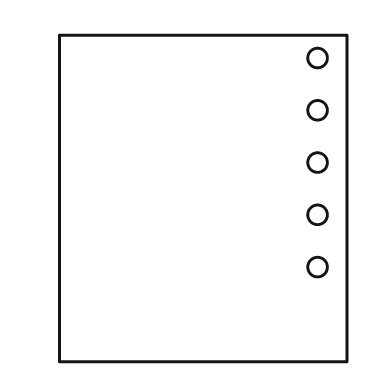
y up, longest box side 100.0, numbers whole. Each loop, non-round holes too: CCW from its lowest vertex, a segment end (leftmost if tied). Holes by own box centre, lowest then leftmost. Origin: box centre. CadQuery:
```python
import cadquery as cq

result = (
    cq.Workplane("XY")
    .moveTo(-44.0, -50.0)
    .lineTo(44.0, -50.0)
    .lineTo(44.0, 50.0)
    .lineTo(-44.0, 50.0)
    .close()
    .moveTo(35.0, -21.0)
    .circle(3.0)
    .moveTo(35.0, -5.0)
    .circle(3.0)
    .moveTo(35.0, 11.0)
    .circle(3.0)
    .moveTo(35.0, 27.0)
    .circle(3.0)
    .moveTo(35.0, 43.0)
    .circle(3.0)
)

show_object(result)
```